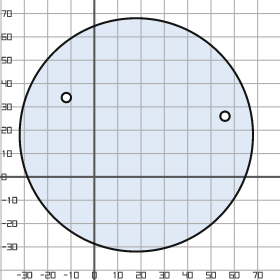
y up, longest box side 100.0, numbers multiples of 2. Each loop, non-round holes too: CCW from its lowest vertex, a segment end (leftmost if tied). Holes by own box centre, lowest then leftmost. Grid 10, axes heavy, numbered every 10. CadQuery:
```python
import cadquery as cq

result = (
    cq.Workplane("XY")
    .moveTo(18.0, 18.0)
    .circle(50.0)
    .moveTo(56.0, 26.0)
    .circle(2.0)
    .moveTo(-12.0, 34.0)
    .circle(2.0)
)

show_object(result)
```